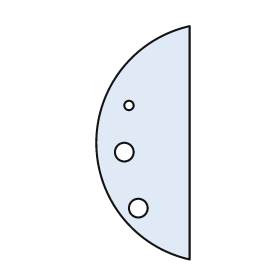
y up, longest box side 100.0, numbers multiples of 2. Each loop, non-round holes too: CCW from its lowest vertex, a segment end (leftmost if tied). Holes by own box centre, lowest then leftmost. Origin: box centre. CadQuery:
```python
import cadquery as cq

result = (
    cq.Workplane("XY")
    .moveTo(20.0, -50.0)
    .lineTo(20.0, 50.0)
    .threePointArc((-20.0, 0.0), (20.0, -50.0))
    .close()
    .moveTo(-2.0, -28.0)
    .circle(4.0)
    .moveTo(-8.0, -4.0)
    .circle(4.0)
    .moveTo(-6.0, 16.0)
    .circle(2.0)
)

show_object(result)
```